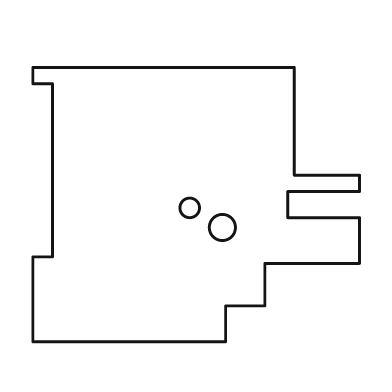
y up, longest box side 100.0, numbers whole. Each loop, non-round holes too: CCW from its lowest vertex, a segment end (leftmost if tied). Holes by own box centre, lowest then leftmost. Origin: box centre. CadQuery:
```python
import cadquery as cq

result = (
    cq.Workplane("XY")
    .moveTo(-50.0, -42.0)
    .lineTo(9.0, -42.0)
    .lineTo(9.0, -31.0)
    .lineTo(21.0, -31.0)
    .lineTo(21.0, -18.0)
    .lineTo(50.0, -18.0)
    .lineTo(50.0, -4.0)
    .lineTo(28.0, -4.0)
    .lineTo(28.0, 4.0)
    .lineTo(50.0, 4.0)
    .lineTo(50.0, 9.0)
    .lineTo(30.0, 9.0)
    .lineTo(30.0, 42.0)
    .lineTo(-50.0, 42.0)
    .lineTo(-50.0, 37.0)
    .lineTo(-44.0, 37.0)
    .lineTo(-44.0, -16.0)
    .lineTo(-50.0, -16.0)
    .close()
    .moveTo(8.0, -7.0)
    .circle(4.0)
    .moveTo(-2.0, -1.0)
    .circle(3.0)
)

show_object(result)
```